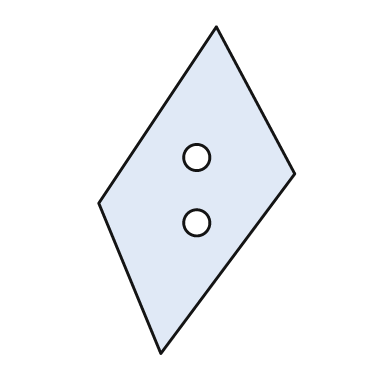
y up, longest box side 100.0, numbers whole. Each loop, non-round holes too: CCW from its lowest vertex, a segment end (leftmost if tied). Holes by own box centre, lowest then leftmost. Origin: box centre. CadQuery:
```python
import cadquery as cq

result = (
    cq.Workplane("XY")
    .moveTo(-11.0, -50.0)
    .lineTo(30.0, 5.0)
    .lineTo(6.0, 50.0)
    .lineTo(-30.0, -4.0)
    .close()
    .moveTo(0.0, -10.0)
    .circle(4.0)
    .moveTo(0.0, 10.0)
    .circle(4.0)
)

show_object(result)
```